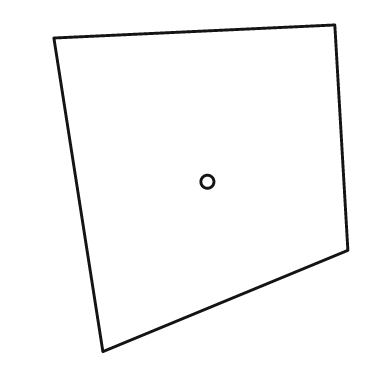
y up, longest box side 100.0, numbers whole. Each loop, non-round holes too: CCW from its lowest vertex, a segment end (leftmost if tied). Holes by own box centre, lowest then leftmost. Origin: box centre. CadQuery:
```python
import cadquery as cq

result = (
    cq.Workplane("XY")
    .moveTo(-30.0, -50.0)
    .lineTo(45.0, -19.0)
    .lineTo(41.0, 50.0)
    .lineTo(-45.0, 46.0)
    .close()
    .moveTo(2.0, 2.0)
    .circle(2.0)
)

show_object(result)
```